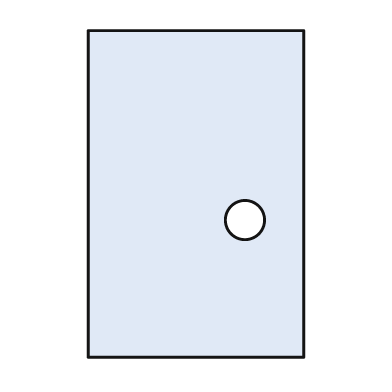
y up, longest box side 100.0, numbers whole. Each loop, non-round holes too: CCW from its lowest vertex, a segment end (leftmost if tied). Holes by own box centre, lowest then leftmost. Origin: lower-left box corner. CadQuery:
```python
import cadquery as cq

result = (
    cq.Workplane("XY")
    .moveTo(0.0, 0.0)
    .lineTo(66.0, 0.0)
    .lineTo(66.0, 100.0)
    .lineTo(0.0, 100.0)
    .close()
    .moveTo(48.0, 42.0)
    .circle(6.0)
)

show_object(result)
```